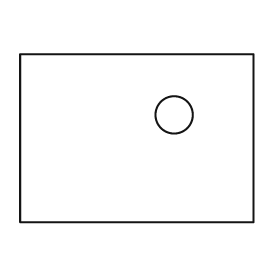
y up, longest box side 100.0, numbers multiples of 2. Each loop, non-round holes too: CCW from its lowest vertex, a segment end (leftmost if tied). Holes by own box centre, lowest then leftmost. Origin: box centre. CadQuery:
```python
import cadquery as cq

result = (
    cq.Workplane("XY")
    .moveTo(-50.0, -36.0)
    .lineTo(50.0, -36.0)
    .lineTo(50.0, 36.0)
    .lineTo(-50.0, 36.0)
    .close()
    .moveTo(16.0, 10.0)
    .circle(8.0)
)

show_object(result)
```